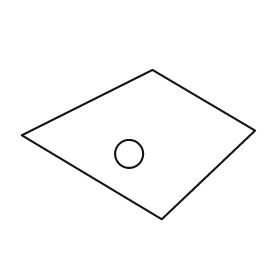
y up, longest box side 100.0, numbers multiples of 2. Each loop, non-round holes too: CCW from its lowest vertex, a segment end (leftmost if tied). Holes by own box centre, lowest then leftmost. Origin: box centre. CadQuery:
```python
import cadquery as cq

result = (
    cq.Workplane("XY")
    .moveTo(10.0, -32.0)
    .lineTo(50.0, 6.0)
    .lineTo(6.0, 32.0)
    .lineTo(-50.0, 4.0)
    .close()
    .moveTo(-4.0, -4.0)
    .circle(6.0)
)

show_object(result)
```